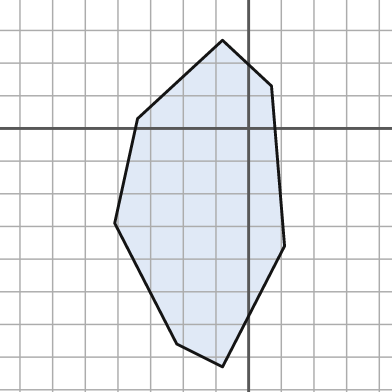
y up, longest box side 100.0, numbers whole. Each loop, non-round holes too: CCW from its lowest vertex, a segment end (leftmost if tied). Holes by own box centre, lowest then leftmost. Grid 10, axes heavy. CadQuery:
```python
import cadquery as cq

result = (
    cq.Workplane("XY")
    .moveTo(-8.0, -73.0)
    .lineTo(11.0, -36.0)
    .lineTo(7.0, 13.0)
    .lineTo(-8.0, 27.0)
    .lineTo(-34.0, 3.0)
    .lineTo(-41.0, -29.0)
    .lineTo(-22.0, -66.0)
    .close()
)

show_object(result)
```